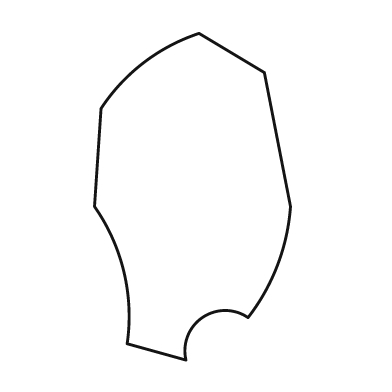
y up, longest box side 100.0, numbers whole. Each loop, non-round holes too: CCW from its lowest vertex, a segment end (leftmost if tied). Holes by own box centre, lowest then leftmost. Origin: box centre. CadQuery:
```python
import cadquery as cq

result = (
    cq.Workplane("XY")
    .moveTo(-2.0, -50.0)
    .threePointArc((3.0, -37.0), (17.0, -37.0))
    .threePointArc((26.0, -21.0), (30.0, -3.0))
    .lineTo(22.0, 38.0)
    .lineTo(2.0, 50.0)
    .threePointArc((-15.0, 41.0), (-28.0, 27.0))
    .lineTo(-30.0, -3.0)
    .threePointArc((-21.0, -23.0), (-20.0, -45.0))
    .close()
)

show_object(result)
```